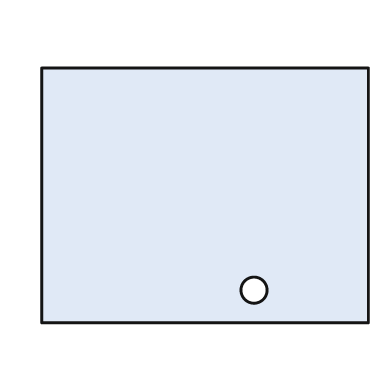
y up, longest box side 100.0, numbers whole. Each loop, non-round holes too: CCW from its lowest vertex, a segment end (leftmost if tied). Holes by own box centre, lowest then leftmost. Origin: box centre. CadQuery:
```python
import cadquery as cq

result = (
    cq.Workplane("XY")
    .moveTo(-50.0, -39.0)
    .lineTo(50.0, -39.0)
    .lineTo(50.0, 39.0)
    .lineTo(-50.0, 39.0)
    .close()
    .moveTo(15.0, -29.0)
    .circle(4.0)
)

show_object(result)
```